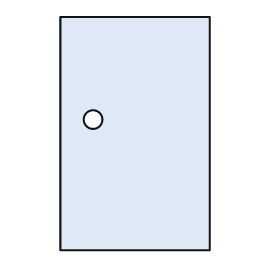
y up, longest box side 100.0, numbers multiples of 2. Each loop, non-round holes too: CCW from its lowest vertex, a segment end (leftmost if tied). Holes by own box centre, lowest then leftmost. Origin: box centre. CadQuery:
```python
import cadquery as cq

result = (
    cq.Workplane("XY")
    .moveTo(-32.0, -50.0)
    .lineTo(32.0, -50.0)
    .lineTo(32.0, 50.0)
    .lineTo(-32.0, 50.0)
    .close()
    .moveTo(-18.0, 6.0)
    .circle(4.0)
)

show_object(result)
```